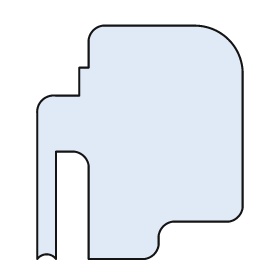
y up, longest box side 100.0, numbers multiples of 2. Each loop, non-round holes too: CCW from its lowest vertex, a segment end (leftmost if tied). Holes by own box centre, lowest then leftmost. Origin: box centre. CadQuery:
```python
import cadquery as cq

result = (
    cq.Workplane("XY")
    .moveTo(-44.0, -50.0)
    .threePointArc((-40.0, -48.0), (-36.0, -50.0))
    .lineTo(-36.0, -4.0)
    .lineTo(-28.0, -4.0)
    .threePointArc((-24.0, -6.0), (-22.0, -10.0))
    .lineTo(-22.0, -50.0)
    .lineTo(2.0, -50.0)
    .threePointArc((6.0, -48.0), (8.0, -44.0))
    .lineTo(8.0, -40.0)
    .threePointArc((10.0, -36.0), (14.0, -34.0))
    .lineTo(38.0, -34.0)
    .threePointArc((42.0, -32.0), (44.0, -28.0))
    .lineTo(44.0, 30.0)
    .threePointArc((38.0, 44.0), (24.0, 50.0))
    .lineTo(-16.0, 50.0)
    .threePointArc((-20.0, 48.0), (-22.0, 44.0))
    .lineTo(-22.0, 32.0)
    .lineTo(-26.0, 32.0)
    .lineTo(-26.0, 20.0)
    .lineTo(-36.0, 20.0)
    .threePointArc((-42.0, 18.0), (-44.0, 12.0))
    .close()
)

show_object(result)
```